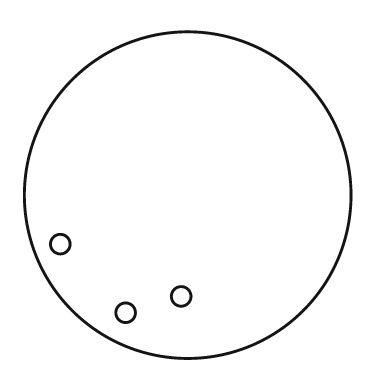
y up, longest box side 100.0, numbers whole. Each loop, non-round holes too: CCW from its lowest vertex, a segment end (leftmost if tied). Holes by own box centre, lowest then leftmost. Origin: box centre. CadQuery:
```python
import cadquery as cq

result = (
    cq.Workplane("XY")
    .moveTo(0.0, 0.0)
    .circle(50.0)
    .moveTo(-19.0, -36.0)
    .circle(3.0)
    .moveTo(-2.0, -31.0)
    .circle(3.0)
    .moveTo(-39.0, -15.0)
    .circle(3.0)
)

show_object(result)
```